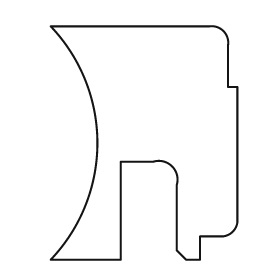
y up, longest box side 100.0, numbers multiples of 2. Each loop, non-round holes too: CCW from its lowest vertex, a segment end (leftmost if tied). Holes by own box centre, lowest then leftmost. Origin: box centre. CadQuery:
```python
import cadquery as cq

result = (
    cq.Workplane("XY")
    .moveTo(-40.0, -50.0)
    .lineTo(-10.0, -50.0)
    .lineTo(-10.0, -8.0)
    .lineTo(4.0, -8.0)
    .threePointArc((12.0, -10.0), (14.0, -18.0))
    .lineTo(14.0, -46.0)
    .lineTo(18.0, -50.0)
    .lineTo(24.0, -50.0)
    .lineTo(24.0, -40.0)
    .lineTo(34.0, -40.0)
    .threePointArc((38.0, -38.0), (40.0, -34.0))
    .lineTo(40.0, 24.0)
    .lineTo(36.0, 24.0)
    .lineTo(36.0, 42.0)
    .threePointArc((34.0, 48.0), (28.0, 50.0))
    .lineTo(-40.0, 50.0)
    .threePointArc((-20.0, 0.0), (-40.0, -50.0))
    .close()
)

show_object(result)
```